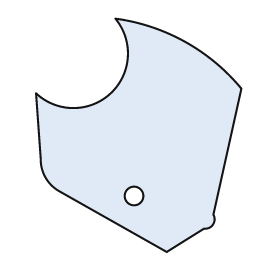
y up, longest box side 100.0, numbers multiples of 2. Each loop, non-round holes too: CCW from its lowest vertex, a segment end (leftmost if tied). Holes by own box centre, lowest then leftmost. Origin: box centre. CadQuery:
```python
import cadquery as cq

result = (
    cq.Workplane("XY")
    .moveTo(12.0, -50.0)
    .lineTo(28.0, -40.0)
    .threePointArc((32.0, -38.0), (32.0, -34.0))
    .lineTo(44.0, 20.0)
    .threePointArc((20.0, 40.0), (-10.0, 50.0))
    .threePointArc((-12.0, 18.0), (-44.0, 18.0))
    .lineTo(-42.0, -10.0)
    .threePointArc((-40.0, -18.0), (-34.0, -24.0))
    .close()
    .moveTo(-2.0, -26.0)
    .circle(4.0)
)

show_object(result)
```